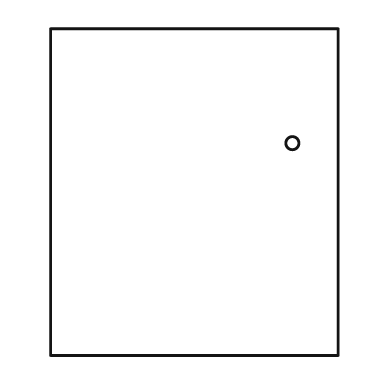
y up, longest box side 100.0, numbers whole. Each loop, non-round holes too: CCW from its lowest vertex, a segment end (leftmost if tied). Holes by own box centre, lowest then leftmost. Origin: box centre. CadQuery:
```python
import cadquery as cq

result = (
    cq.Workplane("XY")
    .moveTo(-44.0, -50.0)
    .lineTo(44.0, -50.0)
    .lineTo(44.0, 50.0)
    .lineTo(-44.0, 50.0)
    .close()
    .moveTo(30.0, 15.0)
    .circle(2.0)
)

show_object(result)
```